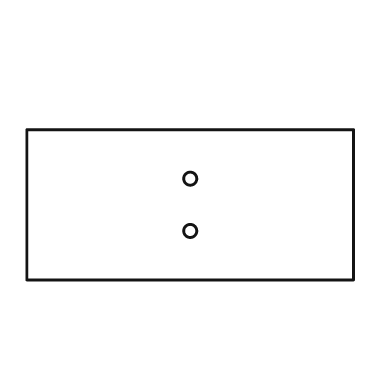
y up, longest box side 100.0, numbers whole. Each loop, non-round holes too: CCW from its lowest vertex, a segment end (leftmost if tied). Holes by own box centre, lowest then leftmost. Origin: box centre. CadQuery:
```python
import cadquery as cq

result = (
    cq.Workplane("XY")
    .moveTo(-50.0, -23.0)
    .lineTo(50.0, -23.0)
    .lineTo(50.0, 23.0)
    .lineTo(-50.0, 23.0)
    .close()
    .moveTo(0.0, -8.0)
    .circle(2.0)
    .moveTo(0.0, 8.0)
    .circle(2.0)
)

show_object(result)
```